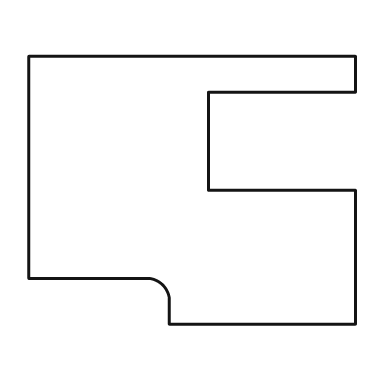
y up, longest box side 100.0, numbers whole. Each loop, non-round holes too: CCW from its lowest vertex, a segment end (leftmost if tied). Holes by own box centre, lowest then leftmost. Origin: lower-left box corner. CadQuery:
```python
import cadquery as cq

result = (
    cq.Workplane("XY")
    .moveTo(43.0, 0.0)
    .lineTo(100.0, 0.0)
    .lineTo(100.0, 41.0)
    .lineTo(55.0, 41.0)
    .lineTo(55.0, 71.0)
    .lineTo(100.0, 71.0)
    .lineTo(100.0, 82.0)
    .lineTo(0.0, 82.0)
    .lineTo(0.0, 14.0)
    .lineTo(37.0, 14.0)
    .threePointArc((41.0, 12.0), (43.0, 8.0))
    .close()
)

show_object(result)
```